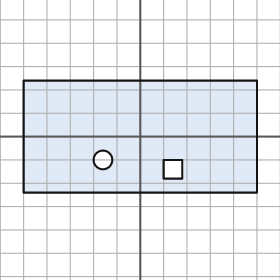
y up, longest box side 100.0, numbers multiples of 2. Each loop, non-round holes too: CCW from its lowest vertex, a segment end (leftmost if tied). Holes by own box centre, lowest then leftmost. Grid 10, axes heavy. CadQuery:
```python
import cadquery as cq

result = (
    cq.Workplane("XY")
    .moveTo(-50.0, -24.0)
    .lineTo(50.0, -24.0)
    .lineTo(50.0, 24.0)
    .lineTo(-50.0, 24.0)
    .close()
    .moveTo(10.0, -18.0)
    .lineTo(18.0, -18.0)
    .lineTo(18.0, -10.0)
    .lineTo(10.0, -10.0)
    .close()
    .moveTo(-16.0, -10.0)
    .circle(4.0)
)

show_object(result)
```